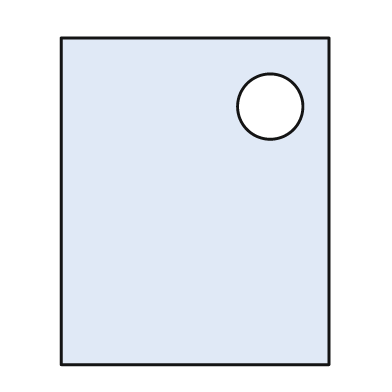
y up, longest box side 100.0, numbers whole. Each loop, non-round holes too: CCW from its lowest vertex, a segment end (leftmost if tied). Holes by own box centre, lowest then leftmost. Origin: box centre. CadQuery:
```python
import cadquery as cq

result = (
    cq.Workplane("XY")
    .moveTo(-41.0, -50.0)
    .lineTo(41.0, -50.0)
    .lineTo(41.0, 50.0)
    .lineTo(-41.0, 50.0)
    .close()
    .moveTo(23.0, 29.0)
    .circle(10.0)
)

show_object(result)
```